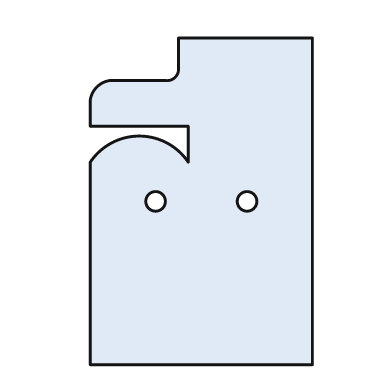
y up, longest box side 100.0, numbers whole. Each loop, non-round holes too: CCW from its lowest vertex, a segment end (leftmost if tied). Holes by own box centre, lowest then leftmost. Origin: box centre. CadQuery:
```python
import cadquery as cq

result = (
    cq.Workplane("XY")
    .moveTo(-34.0, -50.0)
    .lineTo(34.0, -50.0)
    .lineTo(34.0, 50.0)
    .lineTo(-7.0, 50.0)
    .lineTo(-7.0, 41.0)
    .threePointArc((-8.0, 38.0), (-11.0, 37.0))
    .lineTo(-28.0, 37.0)
    .threePointArc((-32.0, 35.0), (-34.0, 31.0))
    .lineTo(-34.0, 23.0)
    .lineTo(-4.0, 23.0)
    .lineTo(-4.0, 12.0)
    .threePointArc((-19.0, 20.0), (-34.0, 12.0))
    .close()
    .moveTo(-14.0, 0.0)
    .circle(3.0)
    .moveTo(14.0, 0.0)
    .circle(3.0)
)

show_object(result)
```